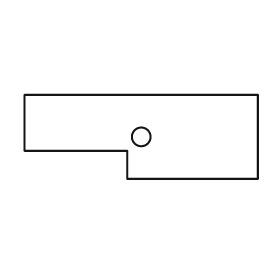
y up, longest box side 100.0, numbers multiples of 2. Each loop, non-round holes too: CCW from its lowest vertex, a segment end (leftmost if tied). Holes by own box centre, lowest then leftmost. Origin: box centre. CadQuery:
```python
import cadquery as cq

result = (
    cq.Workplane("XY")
    .moveTo(-6.0, -18.0)
    .lineTo(50.0, -18.0)
    .lineTo(50.0, 18.0)
    .lineTo(-50.0, 18.0)
    .lineTo(-50.0, -6.0)
    .lineTo(-6.0, -6.0)
    .close()
    .moveTo(0.0, 0.0)
    .circle(4.0)
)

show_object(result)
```